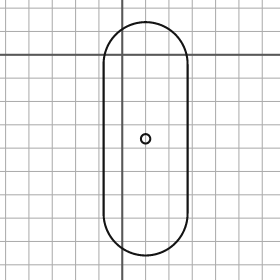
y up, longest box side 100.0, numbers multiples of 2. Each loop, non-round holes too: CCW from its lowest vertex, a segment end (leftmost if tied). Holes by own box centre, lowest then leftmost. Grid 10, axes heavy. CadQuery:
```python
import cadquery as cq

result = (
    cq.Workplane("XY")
    .moveTo(-8.0, -68.0)
    .threePointArc((10.0, -86.0), (28.0, -68.0))
    .lineTo(28.0, -4.0)
    .threePointArc((10.0, 14.0), (-8.0, -4.0))
    .close()
    .moveTo(10.0, -36.0)
    .circle(2.0)
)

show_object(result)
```